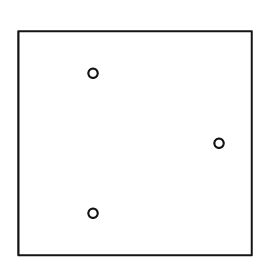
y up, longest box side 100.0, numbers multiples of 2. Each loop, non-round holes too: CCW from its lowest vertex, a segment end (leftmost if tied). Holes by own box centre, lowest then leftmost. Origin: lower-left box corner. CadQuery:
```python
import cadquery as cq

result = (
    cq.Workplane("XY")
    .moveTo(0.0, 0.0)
    .lineTo(100.0, 0.0)
    .lineTo(100.0, 96.0)
    .lineTo(0.0, 96.0)
    .close()
    .moveTo(32.0, 18.0)
    .circle(2.0)
    .moveTo(86.0, 48.0)
    .circle(2.0)
    .moveTo(32.0, 78.0)
    .circle(2.0)
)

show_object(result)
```